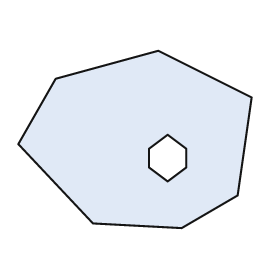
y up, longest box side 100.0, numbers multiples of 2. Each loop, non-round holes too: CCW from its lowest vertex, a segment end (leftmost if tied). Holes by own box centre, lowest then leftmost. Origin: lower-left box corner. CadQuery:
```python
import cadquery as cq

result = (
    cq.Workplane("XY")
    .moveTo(70.0, 0.0)
    .lineTo(94.0, 14.0)
    .lineTo(100.0, 56.0)
    .lineTo(60.0, 76.0)
    .lineTo(16.0, 64.0)
    .lineTo(0.0, 36.0)
    .lineTo(32.0, 2.0)
    .close()
    .moveTo(64.0, 20.0)
    .lineTo(72.0, 26.0)
    .lineTo(72.0, 34.0)
    .lineTo(64.0, 40.0)
    .lineTo(56.0, 34.0)
    .lineTo(56.0, 26.0)
    .close()
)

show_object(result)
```